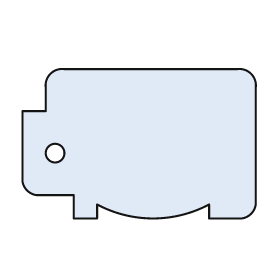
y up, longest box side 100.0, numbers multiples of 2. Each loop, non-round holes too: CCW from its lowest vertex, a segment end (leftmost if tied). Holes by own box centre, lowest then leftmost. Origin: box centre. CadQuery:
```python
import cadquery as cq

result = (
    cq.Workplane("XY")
    .moveTo(-28.0, -32.0)
    .lineTo(-18.0, -32.0)
    .lineTo(-18.0, -26.0)
    .threePointArc((6.0, -32.0), (30.0, -26.0))
    .lineTo(30.0, -32.0)
    .lineTo(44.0, -32.0)
    .threePointArc((48.0, -30.0), (50.0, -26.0))
    .lineTo(50.0, 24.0)
    .threePointArc((48.0, 30.0), (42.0, 32.0))
    .lineTo(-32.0, 32.0)
    .threePointArc((-38.0, 30.0), (-40.0, 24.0))
    .lineTo(-40.0, 14.0)
    .lineTo(-50.0, 14.0)
    .lineTo(-50.0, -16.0)
    .threePointArc((-48.0, -20.0), (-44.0, -22.0))
    .lineTo(-28.0, -22.0)
    .close()
    .moveTo(-36.0, -4.0)
    .circle(4.0)
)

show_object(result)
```